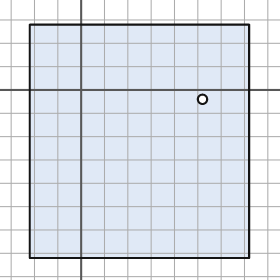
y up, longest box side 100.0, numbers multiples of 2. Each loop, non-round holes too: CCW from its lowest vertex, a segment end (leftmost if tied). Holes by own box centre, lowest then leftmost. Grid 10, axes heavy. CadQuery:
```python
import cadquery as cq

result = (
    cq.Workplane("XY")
    .moveTo(-22.0, -72.0)
    .lineTo(72.0, -72.0)
    .lineTo(72.0, 28.0)
    .lineTo(-22.0, 28.0)
    .close()
    .moveTo(52.0, -4.0)
    .circle(2.0)
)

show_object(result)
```